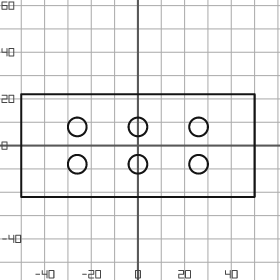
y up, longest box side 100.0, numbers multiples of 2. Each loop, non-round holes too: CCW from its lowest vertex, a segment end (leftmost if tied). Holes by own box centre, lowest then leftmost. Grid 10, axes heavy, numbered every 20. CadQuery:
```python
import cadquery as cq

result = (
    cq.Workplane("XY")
    .moveTo(-50.0, -22.0)
    .lineTo(50.0, -22.0)
    .lineTo(50.0, 22.0)
    .lineTo(-50.0, 22.0)
    .close()
    .moveTo(-26.0, -8.0)
    .circle(4.0)
    .moveTo(0.0, -8.0)
    .circle(4.0)
    .moveTo(26.0, -8.0)
    .circle(4.0)
    .moveTo(-26.0, 8.0)
    .circle(4.0)
    .moveTo(0.0, 8.0)
    .circle(4.0)
    .moveTo(26.0, 8.0)
    .circle(4.0)
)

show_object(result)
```